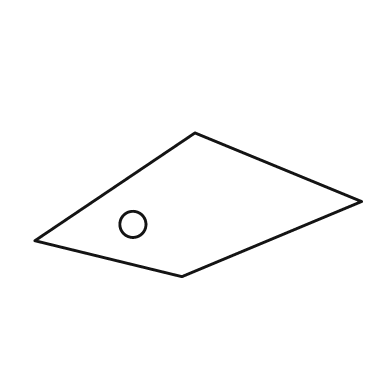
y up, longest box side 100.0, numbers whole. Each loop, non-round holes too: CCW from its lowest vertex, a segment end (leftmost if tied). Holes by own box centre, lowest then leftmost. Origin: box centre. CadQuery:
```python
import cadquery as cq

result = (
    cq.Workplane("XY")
    .moveTo(-5.0, -22.0)
    .lineTo(50.0, 1.0)
    .lineTo(-1.0, 22.0)
    .lineTo(-50.0, -11.0)
    .close()
    .moveTo(-20.0, -6.0)
    .circle(4.0)
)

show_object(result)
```